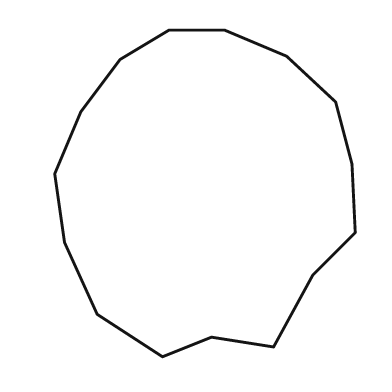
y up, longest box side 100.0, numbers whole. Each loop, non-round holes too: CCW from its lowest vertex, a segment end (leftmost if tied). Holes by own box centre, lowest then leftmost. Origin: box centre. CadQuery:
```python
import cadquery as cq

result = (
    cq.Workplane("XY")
    .moveTo(-13.0, -50.0)
    .lineTo(2.0, -44.0)
    .lineTo(21.0, -47.0)
    .lineTo(33.0, -25.0)
    .lineTo(46.0, -12.0)
    .lineTo(45.0, 9.0)
    .lineTo(40.0, 28.0)
    .lineTo(25.0, 42.0)
    .lineTo(6.0, 50.0)
    .lineTo(-11.0, 50.0)
    .lineTo(-26.0, 41.0)
    .lineTo(-38.0, 25.0)
    .lineTo(-46.0, 6.0)
    .lineTo(-43.0, -15.0)
    .lineTo(-33.0, -37.0)
    .close()
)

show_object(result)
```